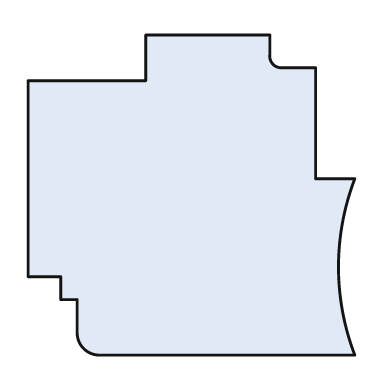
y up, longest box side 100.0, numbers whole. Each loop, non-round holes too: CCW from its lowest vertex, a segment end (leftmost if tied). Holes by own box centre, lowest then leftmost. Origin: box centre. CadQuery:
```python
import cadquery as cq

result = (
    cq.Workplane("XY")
    .moveTo(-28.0, -49.0)
    .lineTo(50.0, -49.0)
    .threePointArc((45.0, -22.0), (50.0, 5.0))
    .lineTo(38.0, 5.0)
    .lineTo(38.0, 39.0)
    .lineTo(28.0, 39.0)
    .threePointArc((25.0, 40.0), (24.0, 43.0))
    .lineTo(24.0, 49.0)
    .lineTo(-14.0, 49.0)
    .lineTo(-14.0, 35.0)
    .lineTo(-50.0, 35.0)
    .lineTo(-50.0, -25.0)
    .lineTo(-40.0, -25.0)
    .lineTo(-40.0, -32.0)
    .lineTo(-35.0, -32.0)
    .lineTo(-35.0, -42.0)
    .threePointArc((-33.0, -47.0), (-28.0, -49.0))
    .close()
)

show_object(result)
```